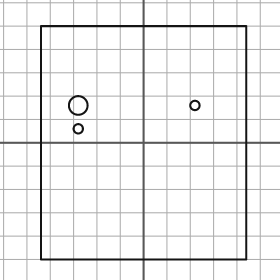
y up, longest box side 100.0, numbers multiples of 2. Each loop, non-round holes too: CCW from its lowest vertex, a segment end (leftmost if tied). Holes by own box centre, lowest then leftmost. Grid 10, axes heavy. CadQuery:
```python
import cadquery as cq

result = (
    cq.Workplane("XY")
    .moveTo(-44.0, -50.0)
    .lineTo(44.0, -50.0)
    .lineTo(44.0, 50.0)
    .lineTo(-44.0, 50.0)
    .close()
    .moveTo(-28.0, 6.0)
    .circle(2.0)
    .moveTo(-28.0, 16.0)
    .circle(4.0)
    .moveTo(22.0, 16.0)
    .circle(2.0)
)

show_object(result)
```